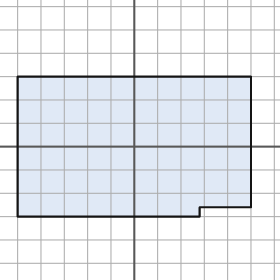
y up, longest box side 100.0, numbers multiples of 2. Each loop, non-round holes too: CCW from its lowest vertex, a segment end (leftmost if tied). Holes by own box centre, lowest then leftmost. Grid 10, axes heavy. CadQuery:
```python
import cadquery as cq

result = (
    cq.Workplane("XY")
    .moveTo(-50.0, -30.0)
    .lineTo(28.0, -30.0)
    .lineTo(28.0, -26.0)
    .lineTo(50.0, -26.0)
    .lineTo(50.0, 30.0)
    .lineTo(-50.0, 30.0)
    .close()
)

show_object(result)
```